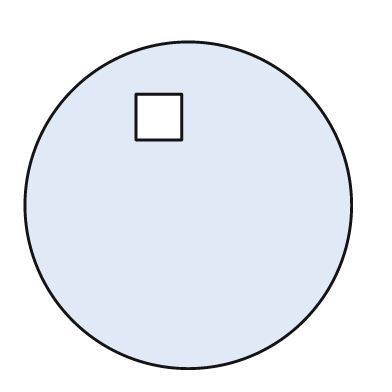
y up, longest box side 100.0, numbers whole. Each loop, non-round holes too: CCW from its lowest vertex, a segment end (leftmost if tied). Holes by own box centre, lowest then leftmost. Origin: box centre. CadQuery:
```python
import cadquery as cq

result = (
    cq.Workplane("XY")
    .moveTo(0.0, 0.0)
    .circle(50.0)
    .moveTo(-16.0, 20.0)
    .lineTo(-2.0, 20.0)
    .lineTo(-2.0, 34.0)
    .lineTo(-16.0, 34.0)
    .close()
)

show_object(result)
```